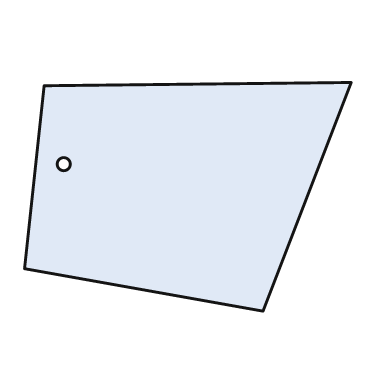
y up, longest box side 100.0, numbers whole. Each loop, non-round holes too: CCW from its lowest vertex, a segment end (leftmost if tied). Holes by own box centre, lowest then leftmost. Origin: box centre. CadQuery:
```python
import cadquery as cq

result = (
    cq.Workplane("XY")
    .moveTo(23.0, -35.0)
    .lineTo(50.0, 35.0)
    .lineTo(-44.0, 34.0)
    .lineTo(-50.0, -22.0)
    .close()
    .moveTo(-38.0, 10.0)
    .circle(2.0)
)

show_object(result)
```